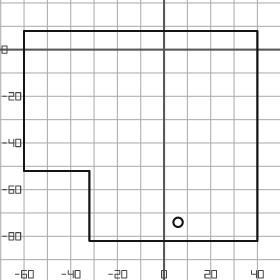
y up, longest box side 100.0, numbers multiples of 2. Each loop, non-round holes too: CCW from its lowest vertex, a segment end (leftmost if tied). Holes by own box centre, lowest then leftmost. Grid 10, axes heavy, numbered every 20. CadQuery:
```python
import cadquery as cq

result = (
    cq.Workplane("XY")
    .moveTo(-32.0, -82.0)
    .lineTo(40.0, -82.0)
    .lineTo(40.0, 8.0)
    .lineTo(-60.0, 8.0)
    .lineTo(-60.0, -52.0)
    .lineTo(-32.0, -52.0)
    .close()
    .moveTo(6.0, -74.0)
    .circle(2.0)
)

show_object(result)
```